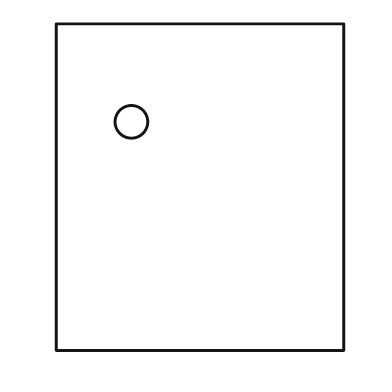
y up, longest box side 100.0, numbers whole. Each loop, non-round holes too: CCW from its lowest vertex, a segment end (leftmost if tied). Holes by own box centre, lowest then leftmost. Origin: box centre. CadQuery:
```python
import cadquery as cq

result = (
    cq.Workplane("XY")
    .moveTo(-44.0, -50.0)
    .lineTo(44.0, -50.0)
    .lineTo(44.0, 50.0)
    .lineTo(-44.0, 50.0)
    .close()
    .moveTo(-21.0, 20.0)
    .circle(5.0)
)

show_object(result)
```